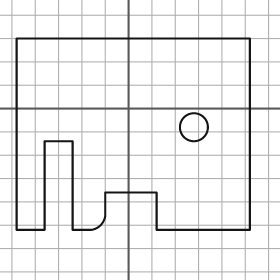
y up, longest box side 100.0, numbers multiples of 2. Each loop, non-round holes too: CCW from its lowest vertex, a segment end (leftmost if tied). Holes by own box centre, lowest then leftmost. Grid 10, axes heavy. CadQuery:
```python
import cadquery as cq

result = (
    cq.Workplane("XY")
    .moveTo(-48.0, -52.0)
    .lineTo(-36.0, -52.0)
    .lineTo(-36.0, -14.0)
    .lineTo(-24.0, -14.0)
    .lineTo(-24.0, -52.0)
    .lineTo(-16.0, -52.0)
    .threePointArc((-12.0, -50.0), (-10.0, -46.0))
    .lineTo(-10.0, -36.0)
    .lineTo(12.0, -36.0)
    .lineTo(12.0, -52.0)
    .lineTo(52.0, -52.0)
    .lineTo(52.0, 30.0)
    .lineTo(-48.0, 30.0)
    .close()
    .moveTo(28.0, -8.0)
    .circle(6.0)
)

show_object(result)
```